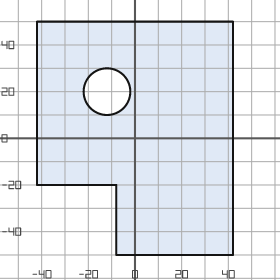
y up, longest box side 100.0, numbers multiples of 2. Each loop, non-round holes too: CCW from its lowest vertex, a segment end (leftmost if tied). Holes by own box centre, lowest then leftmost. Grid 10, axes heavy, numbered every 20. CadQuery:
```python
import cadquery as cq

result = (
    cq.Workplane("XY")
    .moveTo(-8.0, -50.0)
    .lineTo(42.0, -50.0)
    .lineTo(42.0, 50.0)
    .lineTo(-42.0, 50.0)
    .lineTo(-42.0, -20.0)
    .lineTo(-8.0, -20.0)
    .close()
    .moveTo(-12.0, 20.0)
    .circle(10.0)
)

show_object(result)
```